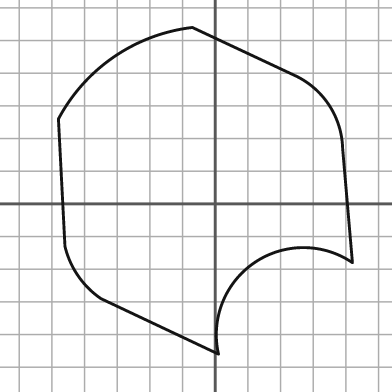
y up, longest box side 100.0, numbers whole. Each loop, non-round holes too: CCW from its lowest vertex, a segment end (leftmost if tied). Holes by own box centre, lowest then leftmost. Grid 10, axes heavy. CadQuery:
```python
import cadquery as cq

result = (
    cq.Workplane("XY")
    .moveTo(1.0, -46.0)
    .threePointArc((12.0, -18.0), (42.0, -18.0))
    .lineTo(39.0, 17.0)
    .threePointArc((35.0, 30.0), (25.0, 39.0))
    .lineTo(-7.0, 54.0)
    .threePointArc((-31.0, 45.0), (-48.0, 26.0))
    .lineTo(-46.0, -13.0)
    .threePointArc((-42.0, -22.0), (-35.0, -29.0))
    .close()
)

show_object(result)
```